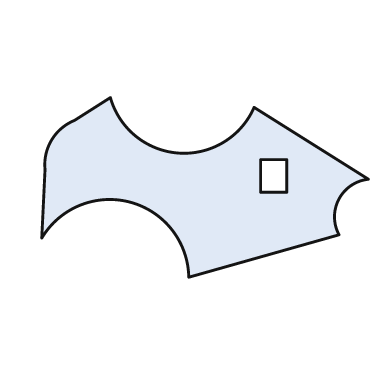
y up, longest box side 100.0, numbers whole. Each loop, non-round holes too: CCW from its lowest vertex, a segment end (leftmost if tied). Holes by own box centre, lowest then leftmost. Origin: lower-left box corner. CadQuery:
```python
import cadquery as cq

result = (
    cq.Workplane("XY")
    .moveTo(45.0, 0.0)
    .lineTo(91.0, 13.0)
    .threePointArc((91.0, 24.0), (100.0, 30.0))
    .lineTo(65.0, 52.0)
    .threePointArc((42.0, 38.0), (21.0, 55.0))
    .lineTo(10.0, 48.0)
    .threePointArc((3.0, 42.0), (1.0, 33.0))
    .lineTo(0.0, 12.0)
    .threePointArc((27.0, 23.0), (45.0, 0.0))
    .close()
    .moveTo(67.0, 26.0)
    .lineTo(75.0, 26.0)
    .lineTo(75.0, 36.0)
    .lineTo(67.0, 36.0)
    .close()
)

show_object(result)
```